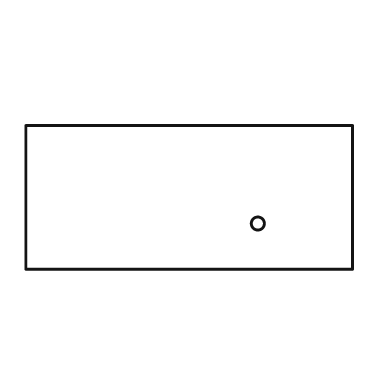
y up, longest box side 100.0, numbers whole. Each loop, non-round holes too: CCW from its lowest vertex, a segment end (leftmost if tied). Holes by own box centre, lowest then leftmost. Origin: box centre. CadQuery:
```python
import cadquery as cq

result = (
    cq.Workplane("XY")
    .moveTo(-50.0, -22.0)
    .lineTo(50.0, -22.0)
    .lineTo(50.0, 22.0)
    .lineTo(-50.0, 22.0)
    .close()
    .moveTo(21.0, -8.0)
    .circle(2.0)
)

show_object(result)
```